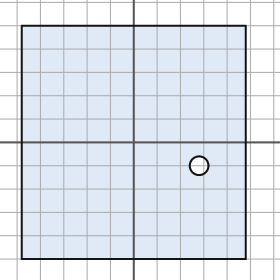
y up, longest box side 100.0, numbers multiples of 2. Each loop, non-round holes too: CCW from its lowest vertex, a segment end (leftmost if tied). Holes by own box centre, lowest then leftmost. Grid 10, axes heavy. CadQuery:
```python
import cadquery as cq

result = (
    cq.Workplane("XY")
    .moveTo(-48.0, -50.0)
    .lineTo(48.0, -50.0)
    .lineTo(48.0, 50.0)
    .lineTo(-48.0, 50.0)
    .close()
    .moveTo(28.0, -10.0)
    .circle(4.0)
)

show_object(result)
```